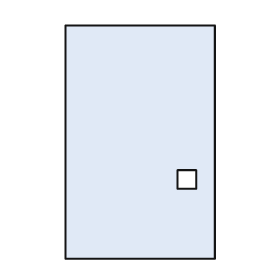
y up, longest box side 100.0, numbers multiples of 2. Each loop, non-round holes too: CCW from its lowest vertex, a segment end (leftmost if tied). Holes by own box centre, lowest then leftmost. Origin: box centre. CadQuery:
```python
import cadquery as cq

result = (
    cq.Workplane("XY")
    .moveTo(-32.0, -50.0)
    .lineTo(32.0, -50.0)
    .lineTo(32.0, 50.0)
    .lineTo(-32.0, 50.0)
    .close()
    .moveTo(16.0, -20.0)
    .lineTo(24.0, -20.0)
    .lineTo(24.0, -12.0)
    .lineTo(16.0, -12.0)
    .close()
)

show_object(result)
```